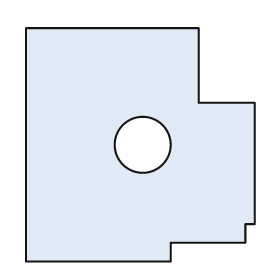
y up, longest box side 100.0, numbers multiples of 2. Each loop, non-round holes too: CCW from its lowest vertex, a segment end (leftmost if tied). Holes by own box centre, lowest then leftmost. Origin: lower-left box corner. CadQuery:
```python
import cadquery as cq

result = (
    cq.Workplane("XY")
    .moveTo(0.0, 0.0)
    .lineTo(62.0, 0.0)
    .lineTo(62.0, 8.0)
    .lineTo(94.0, 8.0)
    .lineTo(94.0, 16.0)
    .lineTo(98.0, 16.0)
    .lineTo(98.0, 68.0)
    .lineTo(74.0, 68.0)
    .lineTo(74.0, 100.0)
    .lineTo(0.0, 100.0)
    .close()
    .moveTo(50.0, 50.0)
    .circle(12.0)
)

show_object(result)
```